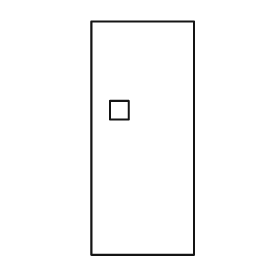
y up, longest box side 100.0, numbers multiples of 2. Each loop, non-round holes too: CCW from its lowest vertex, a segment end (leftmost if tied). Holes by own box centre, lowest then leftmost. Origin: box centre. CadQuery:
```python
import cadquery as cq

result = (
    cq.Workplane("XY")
    .moveTo(-22.0, -50.0)
    .lineTo(22.0, -50.0)
    .lineTo(22.0, 50.0)
    .lineTo(-22.0, 50.0)
    .close()
    .moveTo(-14.0, 8.0)
    .lineTo(-6.0, 8.0)
    .lineTo(-6.0, 16.0)
    .lineTo(-14.0, 16.0)
    .close()
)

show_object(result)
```